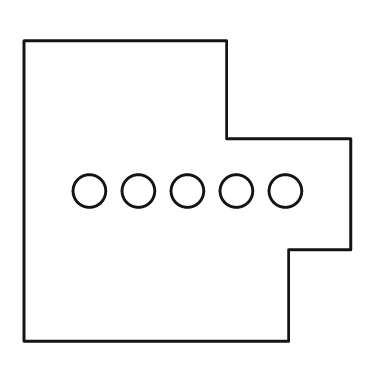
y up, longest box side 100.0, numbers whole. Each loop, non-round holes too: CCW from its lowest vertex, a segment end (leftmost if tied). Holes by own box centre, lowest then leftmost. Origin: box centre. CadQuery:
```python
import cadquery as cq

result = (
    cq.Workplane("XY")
    .moveTo(-50.0, -46.0)
    .lineTo(31.0, -46.0)
    .lineTo(31.0, -18.0)
    .lineTo(50.0, -18.0)
    .lineTo(50.0, 16.0)
    .lineTo(12.0, 16.0)
    .lineTo(12.0, 46.0)
    .lineTo(-50.0, 46.0)
    .close()
    .moveTo(-30.0, 0.0)
    .circle(5.0)
    .moveTo(-15.0, 0.0)
    .circle(5.0)
    .moveTo(0.0, 0.0)
    .circle(5.0)
    .moveTo(15.0, 0.0)
    .circle(5.0)
    .moveTo(30.0, 0.0)
    .circle(5.0)
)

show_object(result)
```